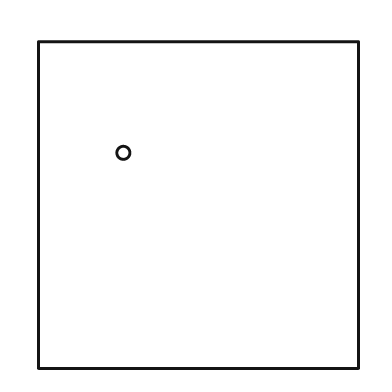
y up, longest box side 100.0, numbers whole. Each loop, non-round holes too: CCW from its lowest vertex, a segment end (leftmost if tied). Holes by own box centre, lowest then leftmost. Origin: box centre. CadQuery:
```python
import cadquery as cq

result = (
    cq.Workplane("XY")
    .moveTo(-49.0, -50.0)
    .lineTo(49.0, -50.0)
    .lineTo(49.0, 50.0)
    .lineTo(-49.0, 50.0)
    .close()
    .moveTo(-23.0, 16.0)
    .circle(2.0)
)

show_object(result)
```